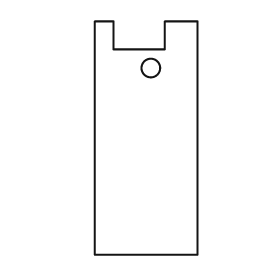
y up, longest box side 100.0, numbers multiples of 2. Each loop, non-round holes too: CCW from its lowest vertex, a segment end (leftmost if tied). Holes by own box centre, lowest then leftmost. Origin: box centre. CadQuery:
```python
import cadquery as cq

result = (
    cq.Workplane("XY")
    .moveTo(-22.0, -50.0)
    .lineTo(22.0, -50.0)
    .lineTo(22.0, 50.0)
    .lineTo(8.0, 50.0)
    .lineTo(8.0, 38.0)
    .lineTo(-14.0, 38.0)
    .lineTo(-14.0, 50.0)
    .lineTo(-22.0, 50.0)
    .close()
    .moveTo(2.0, 30.0)
    .circle(4.0)
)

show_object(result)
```